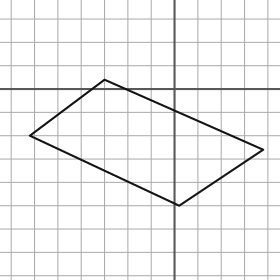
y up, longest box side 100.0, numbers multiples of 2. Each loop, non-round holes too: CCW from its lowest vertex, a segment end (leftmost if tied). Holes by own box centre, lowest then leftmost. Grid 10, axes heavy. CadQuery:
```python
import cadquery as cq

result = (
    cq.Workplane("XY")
    .moveTo(2.0, -50.0)
    .lineTo(38.0, -26.0)
    .lineTo(-30.0, 4.0)
    .lineTo(-62.0, -20.0)
    .close()
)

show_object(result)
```